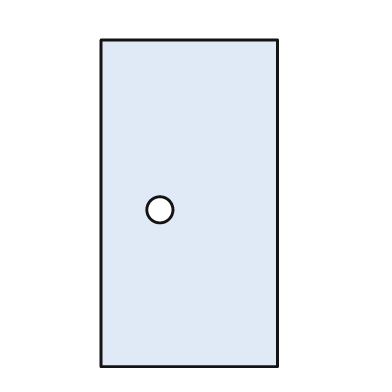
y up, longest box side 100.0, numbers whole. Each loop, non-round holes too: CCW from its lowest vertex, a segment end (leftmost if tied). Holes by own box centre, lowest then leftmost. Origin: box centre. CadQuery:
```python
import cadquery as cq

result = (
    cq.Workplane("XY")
    .moveTo(-27.0, -50.0)
    .lineTo(27.0, -50.0)
    .lineTo(27.0, 50.0)
    .lineTo(-27.0, 50.0)
    .close()
    .moveTo(-9.0, -2.0)
    .circle(4.0)
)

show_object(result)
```